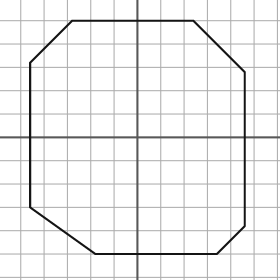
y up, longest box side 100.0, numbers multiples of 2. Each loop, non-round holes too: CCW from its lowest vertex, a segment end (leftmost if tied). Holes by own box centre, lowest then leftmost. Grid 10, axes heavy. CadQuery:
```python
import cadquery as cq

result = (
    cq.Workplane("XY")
    .moveTo(-18.0, -50.0)
    .lineTo(34.0, -50.0)
    .lineTo(46.0, -38.0)
    .lineTo(46.0, 28.0)
    .lineTo(24.0, 50.0)
    .lineTo(-28.0, 50.0)
    .lineTo(-46.0, 32.0)
    .lineTo(-46.0, -30.0)
    .close()
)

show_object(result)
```